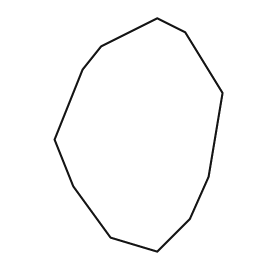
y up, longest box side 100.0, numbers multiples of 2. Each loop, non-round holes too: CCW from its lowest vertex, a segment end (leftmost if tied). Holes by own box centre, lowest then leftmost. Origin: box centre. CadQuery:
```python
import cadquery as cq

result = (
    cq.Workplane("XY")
    .moveTo(8.0, -50.0)
    .lineTo(22.0, -36.0)
    .lineTo(30.0, -18.0)
    .lineTo(36.0, 18.0)
    .lineTo(20.0, 44.0)
    .lineTo(8.0, 50.0)
    .lineTo(-16.0, 38.0)
    .lineTo(-24.0, 28.0)
    .lineTo(-36.0, -2.0)
    .lineTo(-28.0, -22.0)
    .lineTo(-12.0, -44.0)
    .close()
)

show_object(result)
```